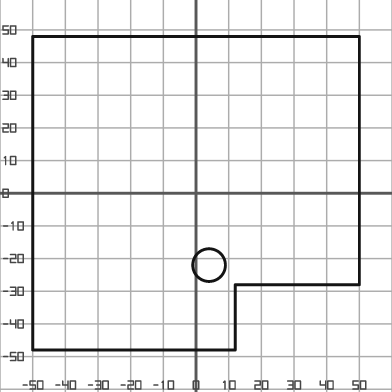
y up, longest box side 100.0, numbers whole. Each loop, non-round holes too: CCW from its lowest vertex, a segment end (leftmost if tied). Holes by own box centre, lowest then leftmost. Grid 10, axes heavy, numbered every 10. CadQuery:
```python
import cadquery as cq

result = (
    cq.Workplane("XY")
    .moveTo(-50.0, -48.0)
    .lineTo(12.0, -48.0)
    .lineTo(12.0, -28.0)
    .lineTo(50.0, -28.0)
    .lineTo(50.0, 48.0)
    .lineTo(-50.0, 48.0)
    .close()
    .moveTo(4.0, -22.0)
    .circle(5.0)
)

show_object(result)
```